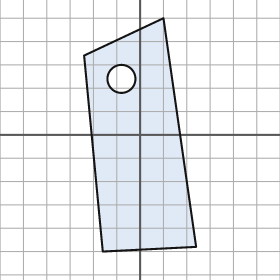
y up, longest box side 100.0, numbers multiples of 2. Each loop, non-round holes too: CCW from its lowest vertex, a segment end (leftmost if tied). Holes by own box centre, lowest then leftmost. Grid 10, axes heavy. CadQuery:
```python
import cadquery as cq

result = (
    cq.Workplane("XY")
    .moveTo(-16.0, -50.0)
    .lineTo(24.0, -48.0)
    .lineTo(10.0, 50.0)
    .lineTo(-24.0, 34.0)
    .close()
    .moveTo(-8.0, 24.0)
    .circle(6.0)
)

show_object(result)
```